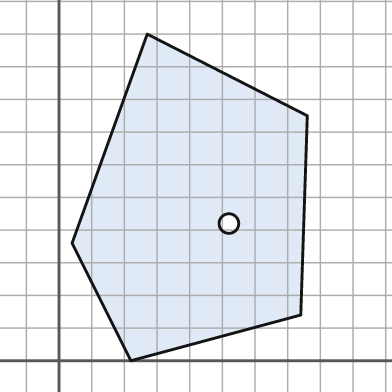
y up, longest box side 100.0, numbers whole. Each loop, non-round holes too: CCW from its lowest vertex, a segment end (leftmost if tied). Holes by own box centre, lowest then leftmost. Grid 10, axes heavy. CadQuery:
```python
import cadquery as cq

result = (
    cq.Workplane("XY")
    .moveTo(22.0, 0.0)
    .lineTo(74.0, 14.0)
    .lineTo(76.0, 75.0)
    .lineTo(27.0, 100.0)
    .lineTo(4.0, 36.0)
    .close()
    .moveTo(52.0, 42.0)
    .circle(3.0)
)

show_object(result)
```